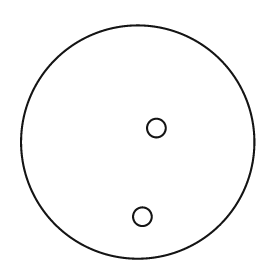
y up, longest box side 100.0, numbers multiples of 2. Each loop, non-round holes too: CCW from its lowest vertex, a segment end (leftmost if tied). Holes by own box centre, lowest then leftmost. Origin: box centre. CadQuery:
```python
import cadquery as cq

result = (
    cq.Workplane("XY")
    .moveTo(0.0, 0.0)
    .circle(50.0)
    .moveTo(2.0, -32.0)
    .circle(4.0)
    .moveTo(8.0, 6.0)
    .circle(4.0)
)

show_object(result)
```